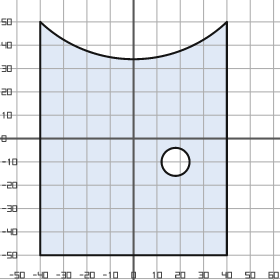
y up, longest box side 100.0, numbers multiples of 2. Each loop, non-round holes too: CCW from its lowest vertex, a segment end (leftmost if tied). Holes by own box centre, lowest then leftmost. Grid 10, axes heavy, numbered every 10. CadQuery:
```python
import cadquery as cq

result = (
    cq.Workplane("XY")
    .moveTo(-40.0, -50.0)
    .lineTo(40.0, -50.0)
    .lineTo(40.0, 50.0)
    .threePointArc((0.0, 34.0), (-40.0, 50.0))
    .close()
    .moveTo(18.0, -10.0)
    .circle(6.0)
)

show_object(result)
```